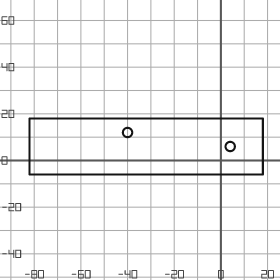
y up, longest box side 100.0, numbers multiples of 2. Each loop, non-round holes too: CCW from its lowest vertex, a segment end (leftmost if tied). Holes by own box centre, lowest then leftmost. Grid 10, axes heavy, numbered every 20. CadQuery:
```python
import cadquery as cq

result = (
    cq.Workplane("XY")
    .moveTo(-82.0, -6.0)
    .lineTo(18.0, -6.0)
    .lineTo(18.0, 18.0)
    .lineTo(-82.0, 18.0)
    .close()
    .moveTo(4.0, 6.0)
    .circle(2.0)
    .moveTo(-40.0, 12.0)
    .circle(2.0)
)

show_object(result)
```